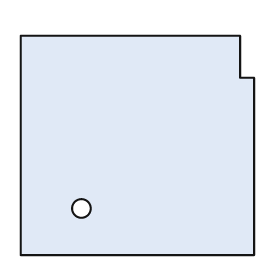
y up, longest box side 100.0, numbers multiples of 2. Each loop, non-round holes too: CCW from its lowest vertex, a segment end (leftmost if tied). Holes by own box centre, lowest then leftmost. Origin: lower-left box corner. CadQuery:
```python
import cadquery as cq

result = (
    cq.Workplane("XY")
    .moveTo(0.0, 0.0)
    .lineTo(100.0, 0.0)
    .lineTo(100.0, 76.0)
    .lineTo(94.0, 76.0)
    .lineTo(94.0, 94.0)
    .lineTo(0.0, 94.0)
    .close()
    .moveTo(26.0, 20.0)
    .circle(4.0)
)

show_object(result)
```